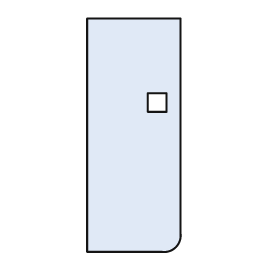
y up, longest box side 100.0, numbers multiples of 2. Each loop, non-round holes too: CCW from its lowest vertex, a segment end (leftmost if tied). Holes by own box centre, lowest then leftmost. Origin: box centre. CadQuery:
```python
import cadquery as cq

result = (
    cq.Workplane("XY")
    .moveTo(-20.0, -50.0)
    .lineTo(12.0, -50.0)
    .threePointArc((18.0, -48.0), (20.0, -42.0))
    .lineTo(20.0, 50.0)
    .lineTo(-20.0, 50.0)
    .close()
    .moveTo(6.0, 10.0)
    .lineTo(14.0, 10.0)
    .lineTo(14.0, 18.0)
    .lineTo(6.0, 18.0)
    .close()
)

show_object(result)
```